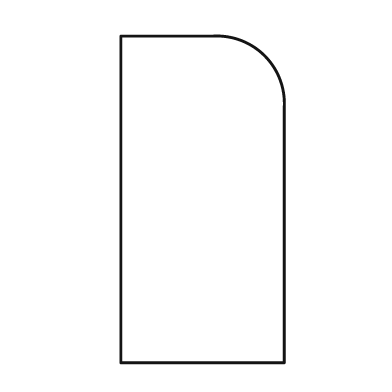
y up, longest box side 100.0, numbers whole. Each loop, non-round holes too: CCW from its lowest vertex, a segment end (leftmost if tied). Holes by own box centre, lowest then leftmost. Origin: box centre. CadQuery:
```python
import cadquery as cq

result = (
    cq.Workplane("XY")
    .moveTo(-25.0, -50.0)
    .lineTo(25.0, -50.0)
    .lineTo(25.0, 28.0)
    .threePointArc((19.0, 44.0), (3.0, 50.0))
    .lineTo(-25.0, 50.0)
    .close()
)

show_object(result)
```